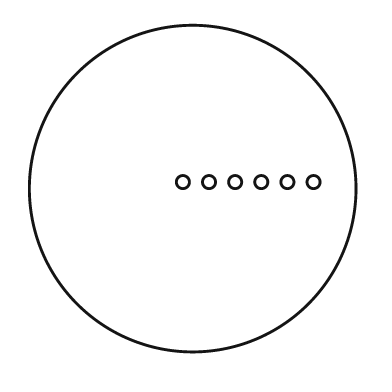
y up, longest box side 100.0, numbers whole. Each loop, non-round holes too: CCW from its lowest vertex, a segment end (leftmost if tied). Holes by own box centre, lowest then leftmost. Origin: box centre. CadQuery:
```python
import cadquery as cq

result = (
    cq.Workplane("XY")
    .moveTo(0.0, 0.0)
    .circle(50.0)
    .moveTo(-3.0, 2.0)
    .circle(2.0)
    .moveTo(5.0, 2.0)
    .circle(2.0)
    .moveTo(13.0, 2.0)
    .circle(2.0)
    .moveTo(21.0, 2.0)
    .circle(2.0)
    .moveTo(29.0, 2.0)
    .circle(2.0)
    .moveTo(37.0, 2.0)
    .circle(2.0)
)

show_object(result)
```